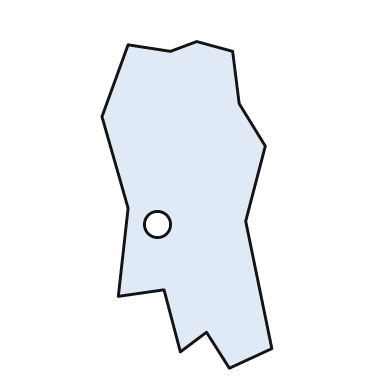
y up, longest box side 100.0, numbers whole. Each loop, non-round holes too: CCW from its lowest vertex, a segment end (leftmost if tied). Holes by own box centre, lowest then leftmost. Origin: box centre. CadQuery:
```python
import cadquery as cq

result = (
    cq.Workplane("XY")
    .moveTo(13.0, -50.0)
    .lineTo(26.0, -44.0)
    .lineTo(18.0, -5.0)
    .lineTo(24.0, 18.0)
    .lineTo(16.0, 31.0)
    .lineTo(14.0, 47.0)
    .lineTo(3.0, 50.0)
    .lineTo(-5.0, 47.0)
    .lineTo(-18.0, 49.0)
    .lineTo(-26.0, 27.0)
    .lineTo(-18.0, -1.0)
    .lineTo(-21.0, -28.0)
    .lineTo(-7.0, -26.0)
    .lineTo(-2.0, -45.0)
    .lineTo(6.0, -39.0)
    .close()
    .moveTo(-9.0, -6.0)
    .circle(4.0)
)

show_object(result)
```